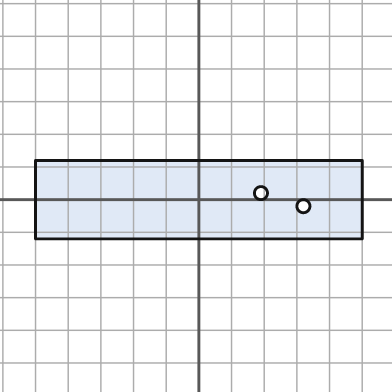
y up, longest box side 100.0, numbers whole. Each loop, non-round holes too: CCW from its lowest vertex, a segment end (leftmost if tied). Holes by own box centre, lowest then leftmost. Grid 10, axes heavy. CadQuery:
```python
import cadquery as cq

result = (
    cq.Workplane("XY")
    .moveTo(-50.0, -12.0)
    .lineTo(50.0, -12.0)
    .lineTo(50.0, 12.0)
    .lineTo(-50.0, 12.0)
    .close()
    .moveTo(32.0, -2.0)
    .circle(2.0)
    .moveTo(19.0, 2.0)
    .circle(2.0)
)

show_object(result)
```